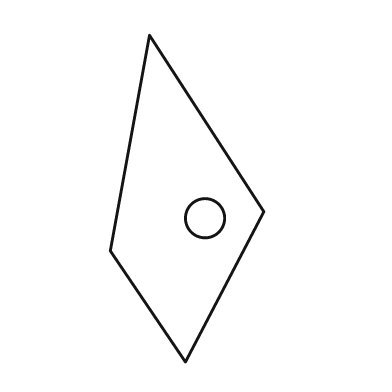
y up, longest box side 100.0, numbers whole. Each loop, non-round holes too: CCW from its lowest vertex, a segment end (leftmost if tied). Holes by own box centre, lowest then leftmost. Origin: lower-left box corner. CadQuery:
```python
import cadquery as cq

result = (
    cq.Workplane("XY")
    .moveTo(23.0, 0.0)
    .lineTo(47.0, 46.0)
    .lineTo(12.0, 100.0)
    .lineTo(0.0, 34.0)
    .close()
    .moveTo(29.0, 44.0)
    .circle(6.0)
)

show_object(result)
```